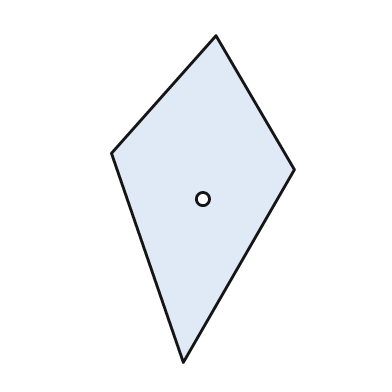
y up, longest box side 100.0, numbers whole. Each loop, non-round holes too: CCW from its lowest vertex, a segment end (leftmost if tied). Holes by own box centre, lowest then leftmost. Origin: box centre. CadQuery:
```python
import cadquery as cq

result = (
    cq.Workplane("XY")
    .moveTo(-6.0, -50.0)
    .lineTo(28.0, 9.0)
    .lineTo(4.0, 50.0)
    .lineTo(-28.0, 14.0)
    .close()
    .moveTo(0.0, 0.0)
    .circle(2.0)
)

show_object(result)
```